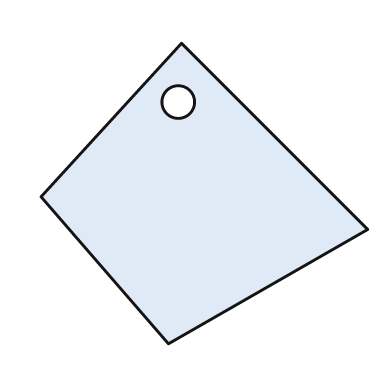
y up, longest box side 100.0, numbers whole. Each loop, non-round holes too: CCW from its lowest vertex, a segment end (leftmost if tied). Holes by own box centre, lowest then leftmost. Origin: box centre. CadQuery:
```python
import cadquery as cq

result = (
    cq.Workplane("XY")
    .moveTo(-11.0, -46.0)
    .lineTo(50.0, -11.0)
    .lineTo(-7.0, 46.0)
    .lineTo(-50.0, -1.0)
    .close()
    .moveTo(-8.0, 28.0)
    .circle(5.0)
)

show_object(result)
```